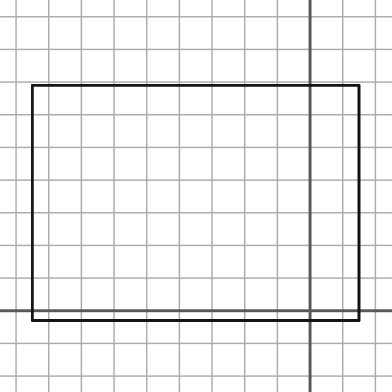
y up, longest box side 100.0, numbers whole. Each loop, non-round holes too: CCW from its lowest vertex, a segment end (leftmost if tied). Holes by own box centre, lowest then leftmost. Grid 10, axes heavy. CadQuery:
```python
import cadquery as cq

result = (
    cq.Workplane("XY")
    .moveTo(-85.0, -3.0)
    .lineTo(15.0, -3.0)
    .lineTo(15.0, 69.0)
    .lineTo(-85.0, 69.0)
    .close()
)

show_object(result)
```